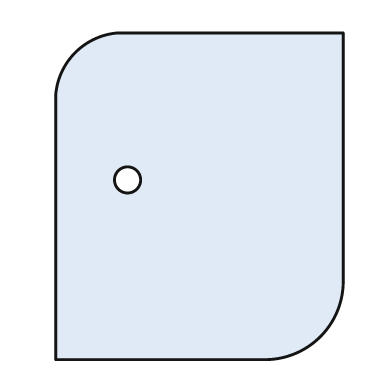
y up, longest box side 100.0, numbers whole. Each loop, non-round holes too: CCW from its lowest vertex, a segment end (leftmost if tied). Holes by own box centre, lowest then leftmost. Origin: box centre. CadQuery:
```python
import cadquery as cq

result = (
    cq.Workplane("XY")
    .moveTo(-44.0, -50.0)
    .lineTo(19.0, -50.0)
    .threePointArc((37.0, -43.0), (44.0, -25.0))
    .lineTo(44.0, 50.0)
    .lineTo(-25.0, 50.0)
    .threePointArc((-38.0, 44.0), (-44.0, 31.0))
    .close()
    .moveTo(-22.0, 5.0)
    .circle(4.0)
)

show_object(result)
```